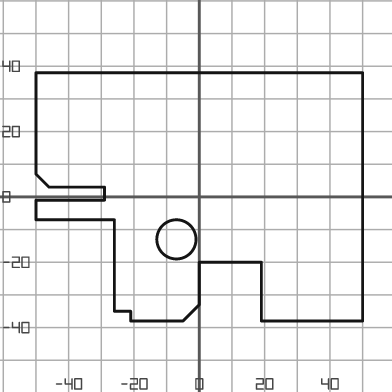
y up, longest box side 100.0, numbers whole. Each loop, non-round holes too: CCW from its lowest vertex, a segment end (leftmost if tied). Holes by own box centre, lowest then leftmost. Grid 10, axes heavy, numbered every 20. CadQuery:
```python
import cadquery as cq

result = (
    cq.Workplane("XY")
    .moveTo(-21.0, -38.0)
    .lineTo(-5.0, -38.0)
    .lineTo(0.0, -33.0)
    .lineTo(0.0, -20.0)
    .lineTo(19.0, -20.0)
    .lineTo(19.0, -38.0)
    .lineTo(50.0, -38.0)
    .lineTo(50.0, 38.0)
    .lineTo(-50.0, 38.0)
    .lineTo(-50.0, 7.0)
    .lineTo(-46.0, 3.0)
    .lineTo(-29.0, 3.0)
    .lineTo(-29.0, -1.0)
    .lineTo(-50.0, -1.0)
    .lineTo(-50.0, -7.0)
    .lineTo(-26.0, -7.0)
    .lineTo(-26.0, -35.0)
    .lineTo(-21.0, -35.0)
    .close()
    .moveTo(-7.0, -13.0)
    .circle(6.0)
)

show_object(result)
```